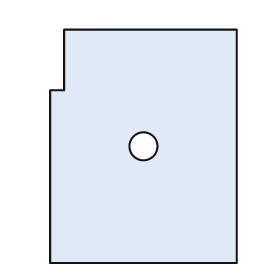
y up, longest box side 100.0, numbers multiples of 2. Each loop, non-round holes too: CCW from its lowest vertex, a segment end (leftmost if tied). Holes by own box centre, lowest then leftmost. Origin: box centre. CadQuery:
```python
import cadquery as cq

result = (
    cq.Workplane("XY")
    .moveTo(-40.0, -50.0)
    .lineTo(40.0, -50.0)
    .lineTo(40.0, 50.0)
    .lineTo(-34.0, 50.0)
    .lineTo(-34.0, 24.0)
    .lineTo(-40.0, 24.0)
    .close()
    .moveTo(0.0, 0.0)
    .circle(6.0)
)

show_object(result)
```